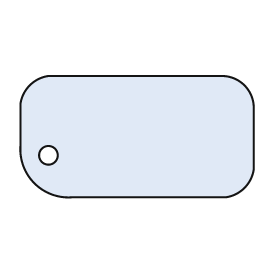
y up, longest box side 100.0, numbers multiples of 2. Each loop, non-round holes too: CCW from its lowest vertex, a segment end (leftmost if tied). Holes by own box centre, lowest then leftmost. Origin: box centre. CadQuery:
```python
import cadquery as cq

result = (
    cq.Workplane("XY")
    .moveTo(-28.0, -26.0)
    .lineTo(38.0, -26.0)
    .threePointArc((46.0, -22.0), (50.0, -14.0))
    .lineTo(50.0, 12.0)
    .threePointArc((46.0, 22.0), (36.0, 26.0))
    .lineTo(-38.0, 26.0)
    .threePointArc((-46.0, 22.0), (-50.0, 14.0))
    .lineTo(-50.0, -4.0)
    .threePointArc((-44.0, -20.0), (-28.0, -26.0))
    .close()
    .moveTo(-38.0, -8.0)
    .circle(4.0)
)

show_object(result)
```